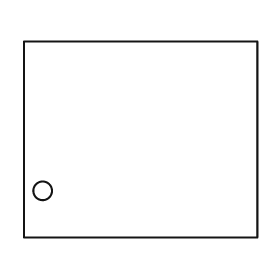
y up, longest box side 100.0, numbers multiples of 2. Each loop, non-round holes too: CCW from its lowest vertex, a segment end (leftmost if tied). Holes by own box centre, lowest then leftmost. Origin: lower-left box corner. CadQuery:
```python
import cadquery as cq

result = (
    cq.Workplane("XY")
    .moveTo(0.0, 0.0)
    .lineTo(100.0, 0.0)
    .lineTo(100.0, 84.0)
    .lineTo(0.0, 84.0)
    .close()
    .moveTo(8.0, 20.0)
    .circle(4.0)
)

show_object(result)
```